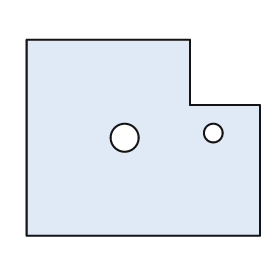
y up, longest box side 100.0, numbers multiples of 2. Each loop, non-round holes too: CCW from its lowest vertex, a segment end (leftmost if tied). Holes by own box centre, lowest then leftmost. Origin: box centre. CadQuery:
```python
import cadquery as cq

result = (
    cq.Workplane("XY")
    .moveTo(-50.0, -42.0)
    .lineTo(50.0, -42.0)
    .lineTo(50.0, 14.0)
    .lineTo(20.0, 14.0)
    .lineTo(20.0, 42.0)
    .lineTo(-50.0, 42.0)
    .close()
    .moveTo(-8.0, 0.0)
    .circle(6.0)
    .moveTo(30.0, 2.0)
    .circle(4.0)
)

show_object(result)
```